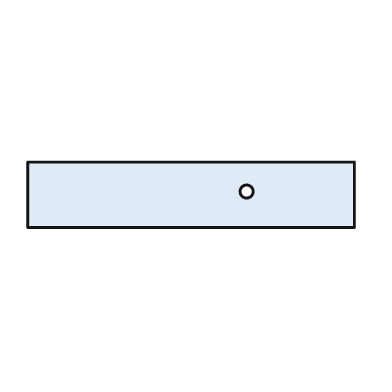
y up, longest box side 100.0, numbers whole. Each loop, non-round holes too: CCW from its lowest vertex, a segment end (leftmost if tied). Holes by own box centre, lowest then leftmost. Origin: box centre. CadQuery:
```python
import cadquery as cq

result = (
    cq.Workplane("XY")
    .moveTo(-50.0, -10.0)
    .lineTo(50.0, -10.0)
    .lineTo(50.0, 10.0)
    .lineTo(-50.0, 10.0)
    .close()
    .moveTo(17.0, 1.0)
    .circle(2.0)
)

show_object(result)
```